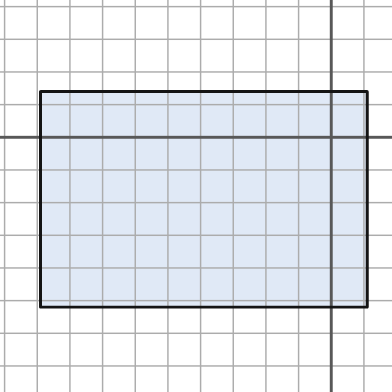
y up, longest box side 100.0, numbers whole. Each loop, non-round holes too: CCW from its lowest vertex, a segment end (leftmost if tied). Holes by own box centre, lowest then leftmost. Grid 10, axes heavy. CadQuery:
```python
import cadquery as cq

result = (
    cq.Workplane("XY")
    .moveTo(-89.0, -52.0)
    .lineTo(11.0, -52.0)
    .lineTo(11.0, 14.0)
    .lineTo(-89.0, 14.0)
    .close()
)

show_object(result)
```